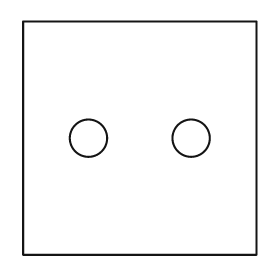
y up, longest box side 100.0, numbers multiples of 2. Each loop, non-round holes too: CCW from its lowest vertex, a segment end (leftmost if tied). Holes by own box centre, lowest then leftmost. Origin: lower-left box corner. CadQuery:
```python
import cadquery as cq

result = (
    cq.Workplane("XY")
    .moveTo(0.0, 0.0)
    .lineTo(100.0, 0.0)
    .lineTo(100.0, 100.0)
    .lineTo(0.0, 100.0)
    .close()
    .moveTo(28.0, 50.0)
    .circle(8.0)
    .moveTo(72.0, 50.0)
    .circle(8.0)
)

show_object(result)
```